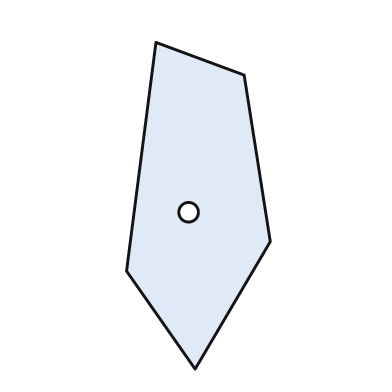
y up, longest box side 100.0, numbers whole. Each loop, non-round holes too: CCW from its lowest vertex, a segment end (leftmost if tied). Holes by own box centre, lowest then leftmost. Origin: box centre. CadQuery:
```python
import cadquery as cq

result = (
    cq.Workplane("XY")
    .moveTo(-1.0, -50.0)
    .lineTo(22.0, -11.0)
    .lineTo(14.0, 40.0)
    .lineTo(-13.0, 50.0)
    .lineTo(-22.0, -20.0)
    .close()
    .moveTo(-3.0, -2.0)
    .circle(3.0)
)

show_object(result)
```